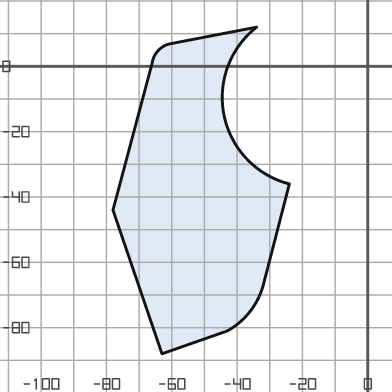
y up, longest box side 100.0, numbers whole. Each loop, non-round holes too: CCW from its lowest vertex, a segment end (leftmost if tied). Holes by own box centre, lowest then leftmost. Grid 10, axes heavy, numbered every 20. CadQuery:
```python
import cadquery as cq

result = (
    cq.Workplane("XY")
    .moveTo(-63.0, -88.0)
    .lineTo(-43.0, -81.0)
    .threePointArc((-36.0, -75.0), (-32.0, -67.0))
    .lineTo(-24.0, -36.0)
    .threePointArc((-44.0, -15.0), (-34.0, 12.0))
    .lineTo(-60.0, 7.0)
    .threePointArc((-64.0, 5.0), (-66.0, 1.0))
    .lineTo(-78.0, -44.0)
    .close()
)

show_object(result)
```